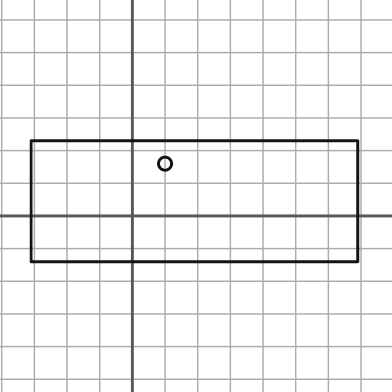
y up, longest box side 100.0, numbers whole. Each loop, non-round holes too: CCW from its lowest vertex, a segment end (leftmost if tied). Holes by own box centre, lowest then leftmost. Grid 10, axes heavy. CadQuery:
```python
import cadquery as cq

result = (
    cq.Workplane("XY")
    .moveTo(-31.0, -14.0)
    .lineTo(69.0, -14.0)
    .lineTo(69.0, 23.0)
    .lineTo(-31.0, 23.0)
    .close()
    .moveTo(10.0, 16.0)
    .circle(2.0)
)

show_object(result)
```